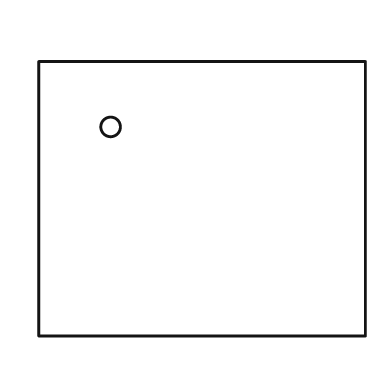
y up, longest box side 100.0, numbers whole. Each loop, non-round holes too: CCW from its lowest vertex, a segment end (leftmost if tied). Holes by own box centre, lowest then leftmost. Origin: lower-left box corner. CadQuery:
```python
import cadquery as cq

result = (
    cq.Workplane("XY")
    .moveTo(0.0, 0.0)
    .lineTo(100.0, 0.0)
    .lineTo(100.0, 84.0)
    .lineTo(0.0, 84.0)
    .close()
    .moveTo(22.0, 64.0)
    .circle(3.0)
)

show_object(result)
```